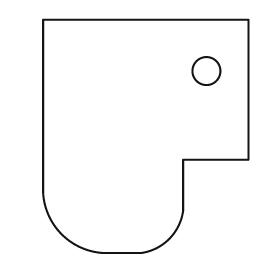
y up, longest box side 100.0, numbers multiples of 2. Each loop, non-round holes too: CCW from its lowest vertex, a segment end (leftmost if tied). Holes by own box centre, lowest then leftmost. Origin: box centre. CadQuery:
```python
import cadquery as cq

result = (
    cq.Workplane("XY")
    .moveTo(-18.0, -50.0)
    .lineTo(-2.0, -50.0)
    .threePointArc((10.0, -44.0), (16.0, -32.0))
    .lineTo(16.0, -10.0)
    .lineTo(44.0, -10.0)
    .lineTo(44.0, 50.0)
    .lineTo(-44.0, 50.0)
    .lineTo(-44.0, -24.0)
    .threePointArc((-36.0, -42.0), (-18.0, -50.0))
    .close()
    .moveTo(26.0, 28.0)
    .circle(6.0)
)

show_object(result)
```